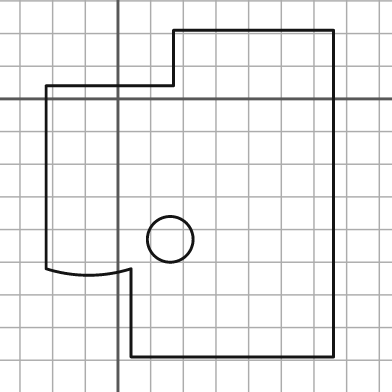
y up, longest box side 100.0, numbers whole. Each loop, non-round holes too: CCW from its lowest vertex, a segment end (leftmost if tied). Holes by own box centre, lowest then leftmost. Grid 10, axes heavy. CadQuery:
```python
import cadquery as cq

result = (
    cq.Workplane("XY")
    .moveTo(4.0, -79.0)
    .lineTo(66.0, -79.0)
    .lineTo(66.0, 21.0)
    .lineTo(17.0, 21.0)
    .lineTo(17.0, 4.0)
    .lineTo(-22.0, 4.0)
    .lineTo(-22.0, -52.0)
    .threePointArc((-9.0, -54.0), (4.0, -52.0))
    .close()
    .moveTo(16.0, -43.0)
    .circle(7.0)
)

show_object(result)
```